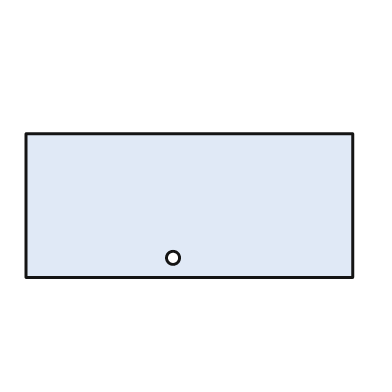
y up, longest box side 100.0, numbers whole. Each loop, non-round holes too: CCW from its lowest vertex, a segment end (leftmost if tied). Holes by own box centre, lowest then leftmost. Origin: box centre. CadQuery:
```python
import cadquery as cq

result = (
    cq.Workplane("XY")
    .moveTo(-50.0, -22.0)
    .lineTo(50.0, -22.0)
    .lineTo(50.0, 22.0)
    .lineTo(-50.0, 22.0)
    .close()
    .moveTo(-5.0, -16.0)
    .circle(2.0)
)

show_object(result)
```